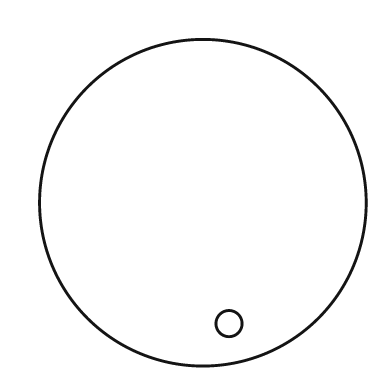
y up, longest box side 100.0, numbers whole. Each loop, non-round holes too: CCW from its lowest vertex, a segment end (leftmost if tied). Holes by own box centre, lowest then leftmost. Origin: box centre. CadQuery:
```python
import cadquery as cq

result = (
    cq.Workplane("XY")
    .moveTo(0.0, 0.0)
    .circle(50.0)
    .moveTo(8.0, -37.0)
    .circle(4.0)
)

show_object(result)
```